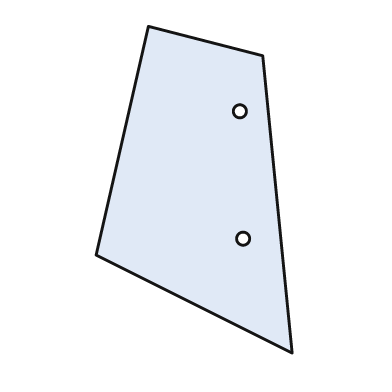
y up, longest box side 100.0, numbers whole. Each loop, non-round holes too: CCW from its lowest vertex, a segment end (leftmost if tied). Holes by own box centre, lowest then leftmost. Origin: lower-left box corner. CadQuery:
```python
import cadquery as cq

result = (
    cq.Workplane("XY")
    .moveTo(60.0, 0.0)
    .lineTo(51.0, 91.0)
    .lineTo(16.0, 100.0)
    .lineTo(0.0, 30.0)
    .close()
    .moveTo(45.0, 35.0)
    .circle(2.0)
    .moveTo(44.0, 74.0)
    .circle(2.0)
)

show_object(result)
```